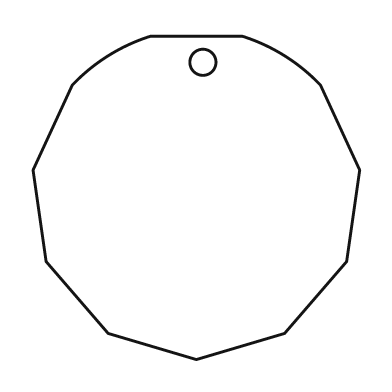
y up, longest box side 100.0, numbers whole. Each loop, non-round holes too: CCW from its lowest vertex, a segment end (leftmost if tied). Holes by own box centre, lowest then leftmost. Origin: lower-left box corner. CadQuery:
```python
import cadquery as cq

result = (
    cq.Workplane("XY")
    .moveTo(50.0, 0.0)
    .lineTo(77.0, 8.0)
    .lineTo(96.0, 30.0)
    .lineTo(100.0, 58.0)
    .lineTo(88.0, 84.0)
    .threePointArc((77.0, 93.0), (64.0, 99.0))
    .lineTo(36.0, 99.0)
    .threePointArc((23.0, 93.0), (12.0, 84.0))
    .lineTo(0.0, 58.0)
    .lineTo(4.0, 30.0)
    .lineTo(23.0, 8.0)
    .close()
    .moveTo(52.0, 91.0)
    .circle(4.0)
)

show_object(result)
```